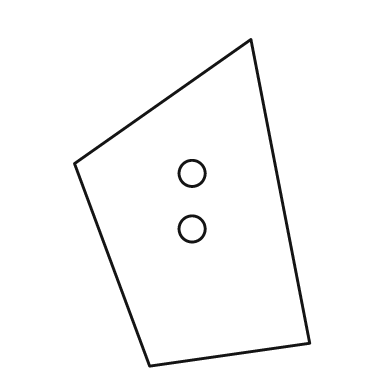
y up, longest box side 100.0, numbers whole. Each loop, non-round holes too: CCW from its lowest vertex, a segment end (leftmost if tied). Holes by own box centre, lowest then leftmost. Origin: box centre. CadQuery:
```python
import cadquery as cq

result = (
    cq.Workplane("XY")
    .moveTo(-13.0, -50.0)
    .lineTo(36.0, -43.0)
    .lineTo(18.0, 50.0)
    .lineTo(-36.0, 12.0)
    .close()
    .moveTo(0.0, -8.0)
    .circle(4.0)
    .moveTo(0.0, 9.0)
    .circle(4.0)
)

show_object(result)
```